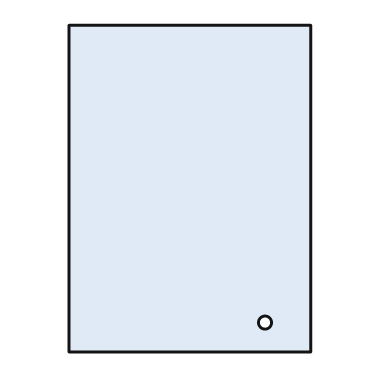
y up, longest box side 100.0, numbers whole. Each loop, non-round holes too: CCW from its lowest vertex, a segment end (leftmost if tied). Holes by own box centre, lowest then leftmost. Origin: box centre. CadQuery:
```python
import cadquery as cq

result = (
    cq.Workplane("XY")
    .moveTo(-37.0, -50.0)
    .lineTo(37.0, -50.0)
    .lineTo(37.0, 50.0)
    .lineTo(-37.0, 50.0)
    .close()
    .moveTo(23.0, -41.0)
    .circle(2.0)
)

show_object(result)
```